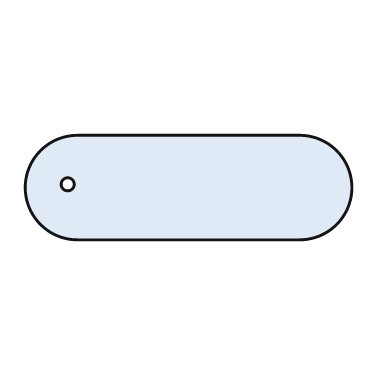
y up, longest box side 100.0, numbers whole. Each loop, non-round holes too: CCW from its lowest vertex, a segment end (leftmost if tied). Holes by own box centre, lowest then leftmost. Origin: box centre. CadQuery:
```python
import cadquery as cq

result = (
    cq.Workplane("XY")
    .moveTo(-34.0, -16.0)
    .lineTo(34.0, -16.0)
    .threePointArc((50.0, 0.0), (34.0, 16.0))
    .lineTo(-34.0, 16.0)
    .threePointArc((-50.0, 0.0), (-34.0, -16.0))
    .close()
    .moveTo(-37.0, 1.0)
    .circle(2.0)
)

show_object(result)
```